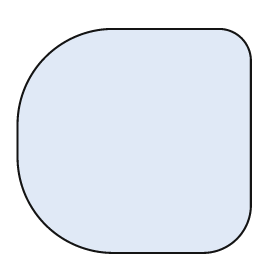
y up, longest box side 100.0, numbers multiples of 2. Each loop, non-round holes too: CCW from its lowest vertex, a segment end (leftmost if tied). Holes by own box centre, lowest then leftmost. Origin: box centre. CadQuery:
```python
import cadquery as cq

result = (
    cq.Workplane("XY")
    .moveTo(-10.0, -48.0)
    .lineTo(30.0, -48.0)
    .threePointArc((44.0, -42.0), (50.0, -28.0))
    .lineTo(50.0, 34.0)
    .threePointArc((46.0, 44.0), (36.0, 48.0))
    .lineTo(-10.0, 48.0)
    .threePointArc((-38.0, 36.0), (-50.0, 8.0))
    .lineTo(-50.0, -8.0)
    .threePointArc((-38.0, -36.0), (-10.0, -48.0))
    .close()
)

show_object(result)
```